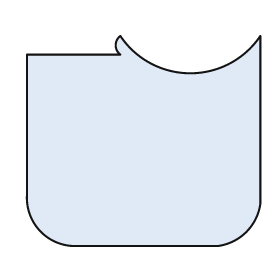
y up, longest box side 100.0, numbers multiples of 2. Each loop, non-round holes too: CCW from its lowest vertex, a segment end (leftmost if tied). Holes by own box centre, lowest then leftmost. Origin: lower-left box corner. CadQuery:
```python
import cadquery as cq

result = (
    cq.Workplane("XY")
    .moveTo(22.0, 0.0)
    .lineTo(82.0, 0.0)
    .threePointArc((94.0, 6.0), (100.0, 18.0))
    .lineTo(100.0, 90.0)
    .threePointArc((70.0, 74.0), (40.0, 90.0))
    .threePointArc((38.0, 86.0), (40.0, 82.0))
    .lineTo(0.0, 82.0)
    .lineTo(0.0, 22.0)
    .threePointArc((6.0, 6.0), (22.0, 0.0))
    .close()
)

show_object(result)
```